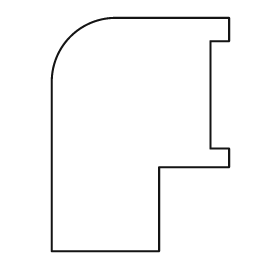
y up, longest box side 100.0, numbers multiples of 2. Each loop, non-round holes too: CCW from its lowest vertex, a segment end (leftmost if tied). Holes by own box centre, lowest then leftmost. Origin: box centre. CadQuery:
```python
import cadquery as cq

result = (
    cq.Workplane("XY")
    .moveTo(-38.0, -50.0)
    .lineTo(8.0, -50.0)
    .lineTo(8.0, -14.0)
    .lineTo(38.0, -14.0)
    .lineTo(38.0, -6.0)
    .lineTo(30.0, -6.0)
    .lineTo(30.0, 40.0)
    .lineTo(38.0, 40.0)
    .lineTo(38.0, 50.0)
    .lineTo(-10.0, 50.0)
    .threePointArc((-30.0, 42.0), (-38.0, 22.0))
    .close()
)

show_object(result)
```